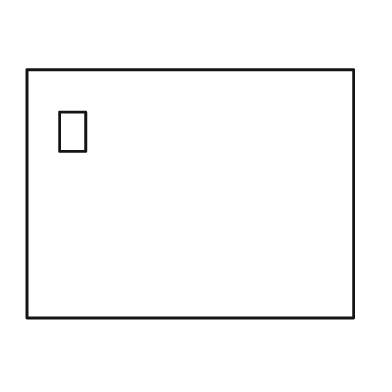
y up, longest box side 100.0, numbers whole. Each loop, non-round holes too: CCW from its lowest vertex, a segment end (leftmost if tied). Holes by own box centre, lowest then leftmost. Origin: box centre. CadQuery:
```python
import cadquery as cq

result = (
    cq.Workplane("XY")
    .moveTo(-50.0, -38.0)
    .lineTo(50.0, -38.0)
    .lineTo(50.0, 38.0)
    .lineTo(-50.0, 38.0)
    .close()
    .moveTo(-40.0, 13.0)
    .lineTo(-32.0, 13.0)
    .lineTo(-32.0, 25.0)
    .lineTo(-40.0, 25.0)
    .close()
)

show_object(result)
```